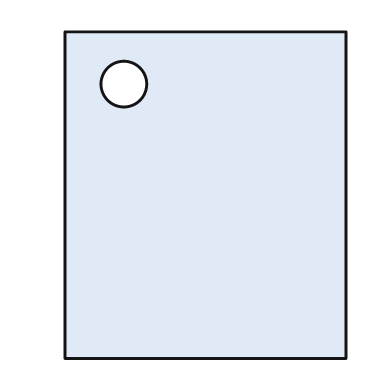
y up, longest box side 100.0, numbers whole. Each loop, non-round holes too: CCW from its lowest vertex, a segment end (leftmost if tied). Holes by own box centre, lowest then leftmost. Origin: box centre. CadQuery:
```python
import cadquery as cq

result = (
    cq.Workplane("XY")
    .moveTo(-43.0, -50.0)
    .lineTo(43.0, -50.0)
    .lineTo(43.0, 50.0)
    .lineTo(-43.0, 50.0)
    .close()
    .moveTo(-25.0, 34.0)
    .circle(7.0)
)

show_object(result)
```